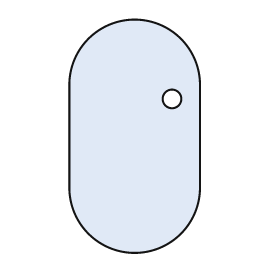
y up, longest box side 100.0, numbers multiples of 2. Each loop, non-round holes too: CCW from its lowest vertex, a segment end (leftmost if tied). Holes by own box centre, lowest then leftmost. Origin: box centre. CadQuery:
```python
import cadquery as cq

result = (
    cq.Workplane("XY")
    .moveTo(-28.0, -22.0)
    .threePointArc((0.0, -50.0), (28.0, -22.0))
    .lineTo(28.0, 22.0)
    .threePointArc((0.0, 50.0), (-28.0, 22.0))
    .close()
    .moveTo(16.0, 16.0)
    .circle(4.0)
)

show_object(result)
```